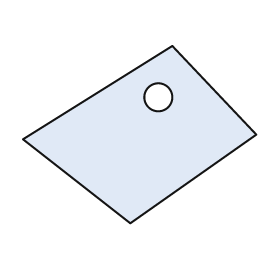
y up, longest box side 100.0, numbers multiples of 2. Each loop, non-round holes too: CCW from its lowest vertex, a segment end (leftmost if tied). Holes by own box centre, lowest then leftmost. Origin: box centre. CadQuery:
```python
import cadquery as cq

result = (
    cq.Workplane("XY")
    .moveTo(-4.0, -38.0)
    .lineTo(50.0, 0.0)
    .lineTo(14.0, 38.0)
    .lineTo(-50.0, -2.0)
    .close()
    .moveTo(8.0, 16.0)
    .circle(6.0)
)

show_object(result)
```